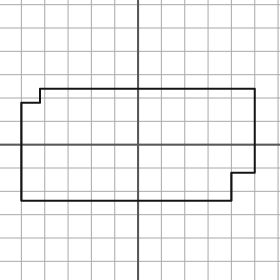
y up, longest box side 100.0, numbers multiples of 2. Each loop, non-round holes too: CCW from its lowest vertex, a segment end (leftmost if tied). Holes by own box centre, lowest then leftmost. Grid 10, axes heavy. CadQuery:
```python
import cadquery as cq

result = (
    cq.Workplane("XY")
    .moveTo(-50.0, -24.0)
    .lineTo(40.0, -24.0)
    .lineTo(40.0, -12.0)
    .lineTo(50.0, -12.0)
    .lineTo(50.0, 24.0)
    .lineTo(-42.0, 24.0)
    .lineTo(-42.0, 18.0)
    .lineTo(-50.0, 18.0)
    .close()
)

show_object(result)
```